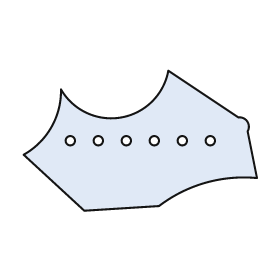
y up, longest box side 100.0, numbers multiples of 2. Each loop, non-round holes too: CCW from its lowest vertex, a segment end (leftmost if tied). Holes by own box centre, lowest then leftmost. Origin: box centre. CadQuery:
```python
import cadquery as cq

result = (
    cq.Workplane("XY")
    .moveTo(-24.0, -30.0)
    .lineTo(8.0, -28.0)
    .threePointArc((28.0, -18.0), (50.0, -16.0))
    .lineTo(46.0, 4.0)
    .threePointArc((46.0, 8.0), (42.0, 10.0))
    .lineTo(12.0, 30.0)
    .threePointArc((-8.0, 10.0), (-34.0, 22.0))
    .threePointArc((-38.0, 6.0), (-50.0, -6.0))
    .close()
    .moveTo(-30.0, 0.0)
    .circle(2.0)
    .moveTo(-18.0, 0.0)
    .circle(2.0)
    .moveTo(-6.0, 0.0)
    .circle(2.0)
    .moveTo(6.0, 0.0)
    .circle(2.0)
    .moveTo(18.0, 0.0)
    .circle(2.0)
    .moveTo(30.0, 0.0)
    .circle(2.0)
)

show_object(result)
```